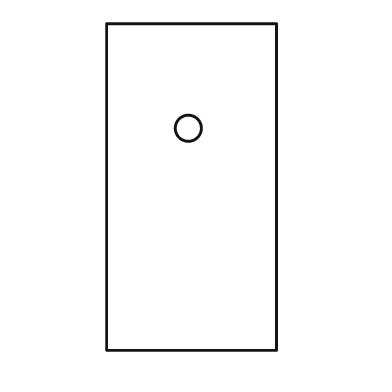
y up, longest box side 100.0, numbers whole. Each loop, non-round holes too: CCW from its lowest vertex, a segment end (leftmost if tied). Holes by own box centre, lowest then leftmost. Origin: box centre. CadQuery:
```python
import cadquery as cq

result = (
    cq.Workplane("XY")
    .moveTo(-26.0, -50.0)
    .lineTo(26.0, -50.0)
    .lineTo(26.0, 50.0)
    .lineTo(-26.0, 50.0)
    .close()
    .moveTo(-1.0, 18.0)
    .circle(4.0)
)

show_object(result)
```